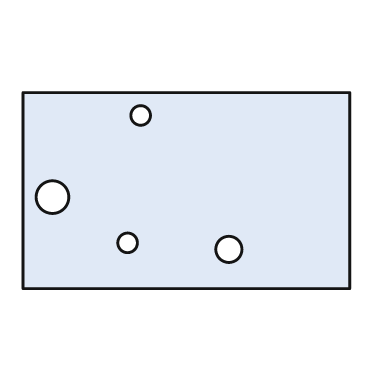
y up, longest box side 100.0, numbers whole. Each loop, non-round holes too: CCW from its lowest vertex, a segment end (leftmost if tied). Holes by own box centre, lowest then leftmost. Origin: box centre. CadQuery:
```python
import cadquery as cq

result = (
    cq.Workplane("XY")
    .moveTo(-50.0, -30.0)
    .lineTo(50.0, -30.0)
    .lineTo(50.0, 30.0)
    .lineTo(-50.0, 30.0)
    .close()
    .moveTo(13.0, -18.0)
    .circle(4.0)
    .moveTo(-18.0, -16.0)
    .circle(3.0)
    .moveTo(-41.0, -2.0)
    .circle(5.0)
    .moveTo(-14.0, 23.0)
    .circle(3.0)
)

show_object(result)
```